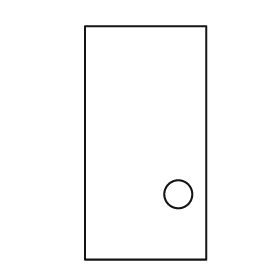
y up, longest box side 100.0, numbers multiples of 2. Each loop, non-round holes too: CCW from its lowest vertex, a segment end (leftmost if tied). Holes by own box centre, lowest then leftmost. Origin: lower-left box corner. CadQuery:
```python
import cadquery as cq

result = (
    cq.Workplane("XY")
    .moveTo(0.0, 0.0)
    .lineTo(52.0, 0.0)
    .lineTo(52.0, 100.0)
    .lineTo(0.0, 100.0)
    .close()
    .moveTo(40.0, 28.0)
    .circle(6.0)
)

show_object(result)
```